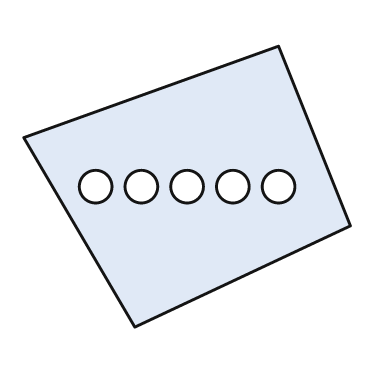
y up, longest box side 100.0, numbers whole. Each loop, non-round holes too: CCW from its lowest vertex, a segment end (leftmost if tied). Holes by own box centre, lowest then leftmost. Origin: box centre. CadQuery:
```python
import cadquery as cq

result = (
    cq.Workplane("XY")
    .moveTo(-16.0, -43.0)
    .lineTo(50.0, -12.0)
    .lineTo(28.0, 43.0)
    .lineTo(-50.0, 15.0)
    .close()
    .moveTo(-28.0, 0.0)
    .circle(5.0)
    .moveTo(-14.0, 0.0)
    .circle(5.0)
    .moveTo(0.0, 0.0)
    .circle(5.0)
    .moveTo(14.0, 0.0)
    .circle(5.0)
    .moveTo(28.0, 0.0)
    .circle(5.0)
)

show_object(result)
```